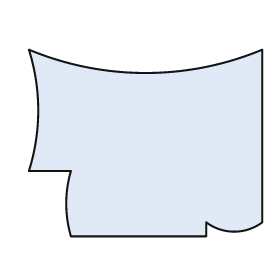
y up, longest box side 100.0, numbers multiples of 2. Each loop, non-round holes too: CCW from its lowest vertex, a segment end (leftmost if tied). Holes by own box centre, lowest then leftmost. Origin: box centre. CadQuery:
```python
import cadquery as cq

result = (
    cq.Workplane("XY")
    .moveTo(-32.0, -40.0)
    .lineTo(26.0, -40.0)
    .lineTo(26.0, -34.0)
    .threePointArc((38.0, -38.0), (50.0, -34.0))
    .lineTo(50.0, 40.0)
    .threePointArc((0.0, 30.0), (-50.0, 40.0))
    .threePointArc((-46.0, 14.0), (-50.0, -12.0))
    .lineTo(-32.0, -12.0)
    .threePointArc((-34.0, -26.0), (-32.0, -40.0))
    .close()
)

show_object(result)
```